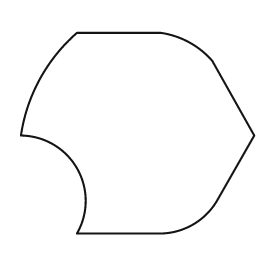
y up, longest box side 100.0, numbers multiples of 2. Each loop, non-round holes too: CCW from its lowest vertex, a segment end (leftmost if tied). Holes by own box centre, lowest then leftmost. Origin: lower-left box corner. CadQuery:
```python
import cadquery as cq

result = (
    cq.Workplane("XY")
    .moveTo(24.0, 0.0)
    .lineTo(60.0, 0.0)
    .threePointArc((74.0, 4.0), (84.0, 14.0))
    .lineTo(100.0, 42.0)
    .lineTo(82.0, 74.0)
    .threePointArc((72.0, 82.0), (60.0, 86.0))
    .lineTo(24.0, 86.0)
    .threePointArc((8.0, 66.0), (0.0, 42.0))
    .threePointArc((24.0, 28.0), (24.0, 0.0))
    .close()
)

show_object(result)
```